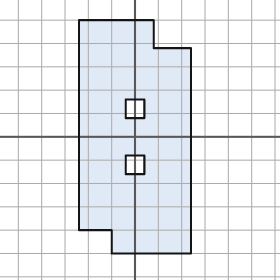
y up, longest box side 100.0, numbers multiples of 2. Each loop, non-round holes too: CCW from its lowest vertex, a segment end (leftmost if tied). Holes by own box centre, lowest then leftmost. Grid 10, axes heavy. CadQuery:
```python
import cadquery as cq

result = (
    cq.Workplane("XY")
    .moveTo(-10.0, -50.0)
    .lineTo(24.0, -50.0)
    .lineTo(24.0, 38.0)
    .lineTo(8.0, 38.0)
    .lineTo(8.0, 50.0)
    .lineTo(-24.0, 50.0)
    .lineTo(-24.0, -40.0)
    .lineTo(-10.0, -40.0)
    .close()
    .moveTo(-4.0, -16.0)
    .lineTo(4.0, -16.0)
    .lineTo(4.0, -8.0)
    .lineTo(-4.0, -8.0)
    .close()
    .moveTo(-4.0, 8.0)
    .lineTo(4.0, 8.0)
    .lineTo(4.0, 16.0)
    .lineTo(-4.0, 16.0)
    .close()
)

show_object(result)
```